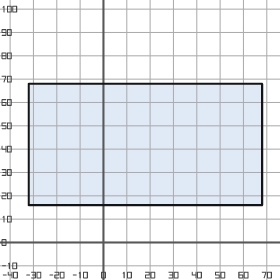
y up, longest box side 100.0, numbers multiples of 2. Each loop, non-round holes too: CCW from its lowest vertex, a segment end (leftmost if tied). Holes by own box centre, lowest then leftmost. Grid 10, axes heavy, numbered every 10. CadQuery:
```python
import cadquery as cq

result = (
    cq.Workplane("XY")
    .moveTo(-32.0, 16.0)
    .lineTo(68.0, 16.0)
    .lineTo(68.0, 68.0)
    .lineTo(-32.0, 68.0)
    .close()
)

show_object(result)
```